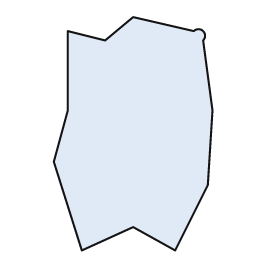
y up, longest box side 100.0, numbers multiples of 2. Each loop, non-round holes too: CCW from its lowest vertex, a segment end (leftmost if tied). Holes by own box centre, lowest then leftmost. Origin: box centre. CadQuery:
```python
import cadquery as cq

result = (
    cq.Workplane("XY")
    .moveTo(-22.0, -50.0)
    .lineTo(0.0, -40.0)
    .lineTo(18.0, -50.0)
    .lineTo(32.0, -22.0)
    .lineTo(34.0, 10.0)
    .lineTo(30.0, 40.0)
    .threePointArc((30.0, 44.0), (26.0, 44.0))
    .lineTo(0.0, 50.0)
    .lineTo(-12.0, 40.0)
    .lineTo(-28.0, 44.0)
    .lineTo(-28.0, 10.0)
    .lineTo(-34.0, -12.0)
    .close()
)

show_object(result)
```